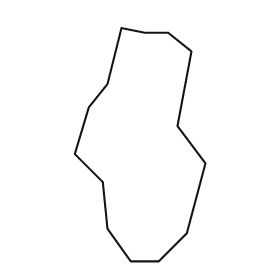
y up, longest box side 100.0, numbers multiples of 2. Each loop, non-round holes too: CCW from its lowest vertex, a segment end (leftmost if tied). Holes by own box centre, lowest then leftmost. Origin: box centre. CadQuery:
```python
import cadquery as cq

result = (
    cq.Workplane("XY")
    .moveTo(-4.0, -50.0)
    .lineTo(8.0, -50.0)
    .lineTo(20.0, -38.0)
    .lineTo(28.0, -8.0)
    .lineTo(16.0, 8.0)
    .lineTo(22.0, 40.0)
    .lineTo(12.0, 48.0)
    .lineTo(2.0, 48.0)
    .lineTo(-8.0, 50.0)
    .lineTo(-14.0, 26.0)
    .lineTo(-22.0, 16.0)
    .lineTo(-28.0, -4.0)
    .lineTo(-16.0, -16.0)
    .lineTo(-14.0, -36.0)
    .close()
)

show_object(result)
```